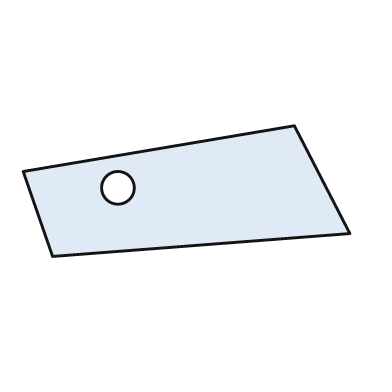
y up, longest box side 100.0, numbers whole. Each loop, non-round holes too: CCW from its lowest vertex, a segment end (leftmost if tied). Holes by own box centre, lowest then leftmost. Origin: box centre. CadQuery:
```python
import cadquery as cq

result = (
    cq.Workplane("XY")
    .moveTo(-41.0, -20.0)
    .lineTo(50.0, -13.0)
    .lineTo(33.0, 20.0)
    .lineTo(-50.0, 6.0)
    .close()
    .moveTo(-21.0, 1.0)
    .circle(5.0)
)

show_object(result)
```